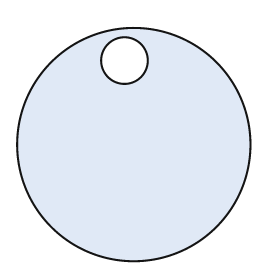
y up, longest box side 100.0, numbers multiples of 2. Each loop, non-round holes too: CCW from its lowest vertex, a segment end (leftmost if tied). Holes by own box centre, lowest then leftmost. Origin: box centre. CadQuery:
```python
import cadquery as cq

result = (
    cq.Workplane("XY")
    .moveTo(0.0, 0.0)
    .circle(50.0)
    .moveTo(-4.0, 36.0)
    .circle(10.0)
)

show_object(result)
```